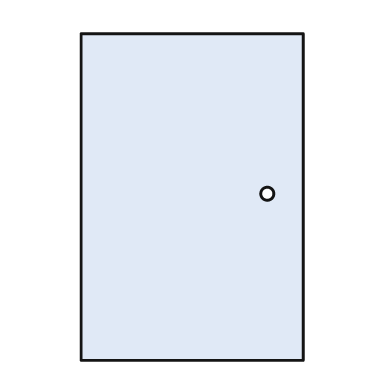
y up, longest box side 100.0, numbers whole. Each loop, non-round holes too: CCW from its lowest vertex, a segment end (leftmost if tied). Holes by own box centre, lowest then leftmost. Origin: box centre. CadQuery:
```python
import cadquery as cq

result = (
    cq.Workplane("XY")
    .moveTo(-34.0, -50.0)
    .lineTo(34.0, -50.0)
    .lineTo(34.0, 50.0)
    .lineTo(-34.0, 50.0)
    .close()
    .moveTo(23.0, 1.0)
    .circle(2.0)
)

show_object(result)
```